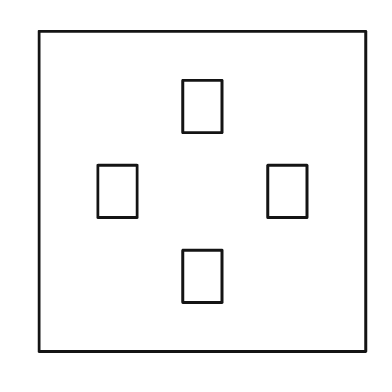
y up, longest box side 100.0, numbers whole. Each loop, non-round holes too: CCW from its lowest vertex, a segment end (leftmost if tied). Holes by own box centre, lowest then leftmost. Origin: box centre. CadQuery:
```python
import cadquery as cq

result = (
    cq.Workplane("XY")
    .moveTo(-50.0, -49.0)
    .lineTo(50.0, -49.0)
    .lineTo(50.0, 49.0)
    .lineTo(-50.0, 49.0)
    .close()
    .moveTo(-6.0, -34.0)
    .lineTo(6.0, -34.0)
    .lineTo(6.0, -18.0)
    .lineTo(-6.0, -18.0)
    .close()
    .moveTo(-32.0, -8.0)
    .lineTo(-20.0, -8.0)
    .lineTo(-20.0, 8.0)
    .lineTo(-32.0, 8.0)
    .close()
    .moveTo(20.0, -8.0)
    .lineTo(32.0, -8.0)
    .lineTo(32.0, 8.0)
    .lineTo(20.0, 8.0)
    .close()
    .moveTo(-6.0, 18.0)
    .lineTo(6.0, 18.0)
    .lineTo(6.0, 34.0)
    .lineTo(-6.0, 34.0)
    .close()
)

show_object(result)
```